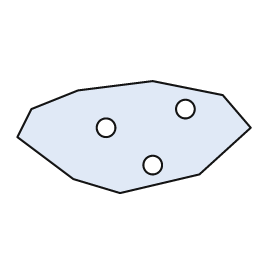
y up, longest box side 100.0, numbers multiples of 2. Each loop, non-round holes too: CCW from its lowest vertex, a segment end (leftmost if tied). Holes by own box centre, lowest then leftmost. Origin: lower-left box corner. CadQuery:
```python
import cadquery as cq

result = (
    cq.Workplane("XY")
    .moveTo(44.0, 0.0)
    .lineTo(78.0, 8.0)
    .lineTo(100.0, 28.0)
    .lineTo(88.0, 42.0)
    .lineTo(58.0, 48.0)
    .lineTo(26.0, 44.0)
    .lineTo(6.0, 36.0)
    .lineTo(0.0, 24.0)
    .lineTo(24.0, 6.0)
    .close()
    .moveTo(58.0, 12.0)
    .circle(4.0)
    .moveTo(38.0, 28.0)
    .circle(4.0)
    .moveTo(72.0, 36.0)
    .circle(4.0)
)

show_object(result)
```